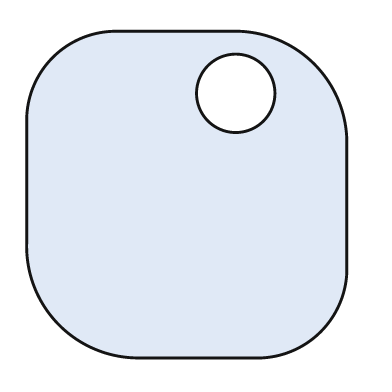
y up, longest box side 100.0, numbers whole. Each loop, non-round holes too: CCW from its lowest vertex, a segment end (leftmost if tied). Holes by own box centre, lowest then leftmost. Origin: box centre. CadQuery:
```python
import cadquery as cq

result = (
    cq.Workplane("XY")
    .moveTo(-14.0, -50.0)
    .lineTo(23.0, -50.0)
    .threePointArc((41.0, -42.0), (49.0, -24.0))
    .lineTo(49.0, 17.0)
    .threePointArc((39.0, 40.0), (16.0, 50.0))
    .lineTo(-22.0, 50.0)
    .threePointArc((-41.0, 42.0), (-49.0, 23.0))
    .lineTo(-49.0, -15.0)
    .threePointArc((-39.0, -40.0), (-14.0, -50.0))
    .close()
    .moveTo(15.0, 31.0)
    .circle(12.0)
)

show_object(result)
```